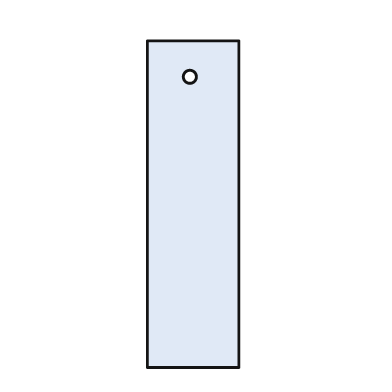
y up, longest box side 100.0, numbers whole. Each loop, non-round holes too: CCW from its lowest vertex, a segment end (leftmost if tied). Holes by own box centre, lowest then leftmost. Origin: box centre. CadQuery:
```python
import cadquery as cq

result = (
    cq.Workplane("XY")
    .moveTo(-14.0, -50.0)
    .lineTo(14.0, -50.0)
    .lineTo(14.0, 50.0)
    .lineTo(-14.0, 50.0)
    .close()
    .moveTo(-1.0, 39.0)
    .circle(2.0)
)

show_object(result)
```